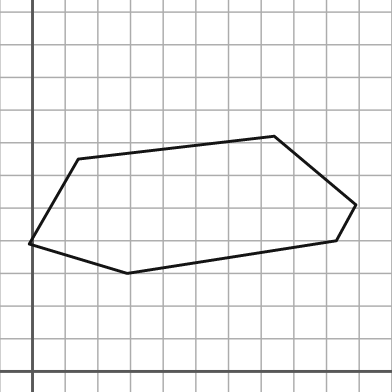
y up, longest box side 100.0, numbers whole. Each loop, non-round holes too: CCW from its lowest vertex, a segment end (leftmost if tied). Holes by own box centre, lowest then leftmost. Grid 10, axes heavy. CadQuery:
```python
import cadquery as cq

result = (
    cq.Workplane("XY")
    .moveTo(29.0, 30.0)
    .lineTo(93.0, 40.0)
    .lineTo(99.0, 51.0)
    .lineTo(74.0, 72.0)
    .lineTo(14.0, 65.0)
    .lineTo(-1.0, 39.0)
    .close()
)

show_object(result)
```